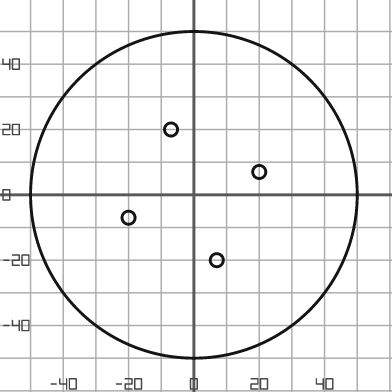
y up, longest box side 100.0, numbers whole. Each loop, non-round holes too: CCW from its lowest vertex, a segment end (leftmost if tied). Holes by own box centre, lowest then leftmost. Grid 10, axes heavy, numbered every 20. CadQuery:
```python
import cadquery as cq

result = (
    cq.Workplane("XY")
    .moveTo(0.0, 0.0)
    .circle(50.0)
    .moveTo(7.0, -20.0)
    .circle(2.0)
    .moveTo(-20.0, -7.0)
    .circle(2.0)
    .moveTo(20.0, 7.0)
    .circle(2.0)
    .moveTo(-7.0, 20.0)
    .circle(2.0)
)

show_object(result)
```